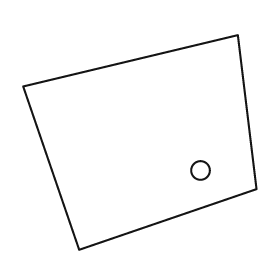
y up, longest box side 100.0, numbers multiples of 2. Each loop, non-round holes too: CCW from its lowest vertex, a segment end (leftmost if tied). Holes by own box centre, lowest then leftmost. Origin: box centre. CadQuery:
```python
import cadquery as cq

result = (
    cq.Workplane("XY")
    .moveTo(-26.0, -46.0)
    .lineTo(50.0, -20.0)
    .lineTo(42.0, 46.0)
    .lineTo(-50.0, 24.0)
    .close()
    .moveTo(26.0, -12.0)
    .circle(4.0)
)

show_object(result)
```